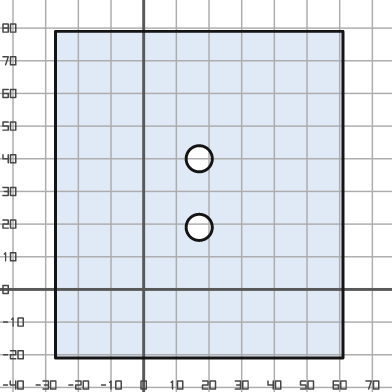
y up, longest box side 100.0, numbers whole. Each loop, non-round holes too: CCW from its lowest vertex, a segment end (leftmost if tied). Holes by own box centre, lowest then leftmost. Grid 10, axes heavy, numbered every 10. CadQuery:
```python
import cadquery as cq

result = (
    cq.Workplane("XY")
    .moveTo(-27.0, -21.0)
    .lineTo(61.0, -21.0)
    .lineTo(61.0, 79.0)
    .lineTo(-27.0, 79.0)
    .close()
    .moveTo(17.0, 19.0)
    .circle(4.0)
    .moveTo(17.0, 40.0)
    .circle(4.0)
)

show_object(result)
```